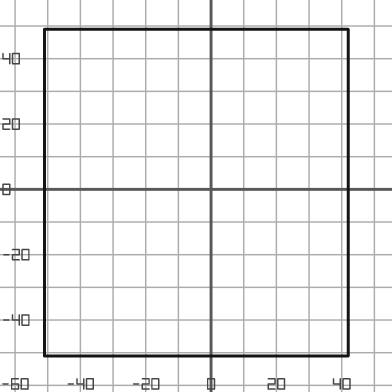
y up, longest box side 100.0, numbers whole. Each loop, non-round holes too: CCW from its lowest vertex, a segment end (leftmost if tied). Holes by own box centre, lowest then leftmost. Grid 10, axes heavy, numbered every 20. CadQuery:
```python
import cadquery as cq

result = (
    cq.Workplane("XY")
    .moveTo(-51.0, -51.0)
    .lineTo(42.0, -51.0)
    .lineTo(42.0, 49.0)
    .lineTo(-51.0, 49.0)
    .close()
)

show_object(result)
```